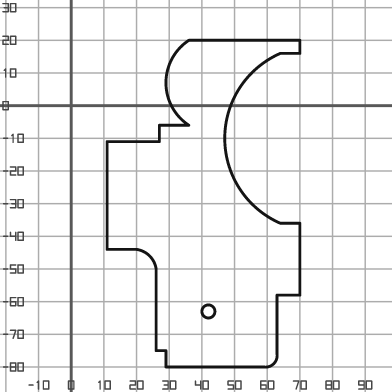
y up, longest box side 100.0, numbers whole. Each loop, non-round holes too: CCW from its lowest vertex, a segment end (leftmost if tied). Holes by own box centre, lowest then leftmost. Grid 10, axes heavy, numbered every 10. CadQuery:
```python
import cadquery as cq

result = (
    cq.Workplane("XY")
    .moveTo(29.0, -80.0)
    .lineTo(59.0, -80.0)
    .threePointArc((62.0, -79.0), (63.0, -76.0))
    .lineTo(63.0, -58.0)
    .lineTo(70.0, -58.0)
    .lineTo(70.0, -36.0)
    .lineTo(64.0, -36.0)
    .threePointArc((47.0, -10.0), (64.0, 16.0))
    .lineTo(70.0, 16.0)
    .lineTo(70.0, 20.0)
    .lineTo(36.0, 20.0)
    .threePointArc((29.0, 7.0), (36.0, -6.0))
    .lineTo(27.0, -6.0)
    .lineTo(27.0, -11.0)
    .lineTo(11.0, -11.0)
    .lineTo(11.0, -44.0)
    .lineTo(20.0, -44.0)
    .threePointArc((24.0, -46.0), (26.0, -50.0))
    .lineTo(26.0, -75.0)
    .lineTo(29.0, -75.0)
    .close()
    .moveTo(42.0, -63.0)
    .circle(2.0)
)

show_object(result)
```